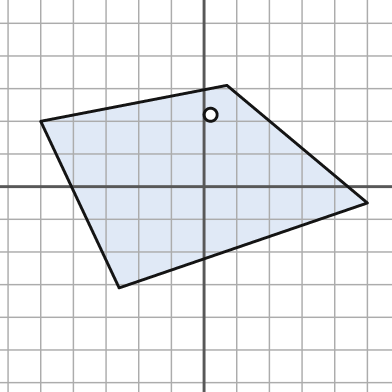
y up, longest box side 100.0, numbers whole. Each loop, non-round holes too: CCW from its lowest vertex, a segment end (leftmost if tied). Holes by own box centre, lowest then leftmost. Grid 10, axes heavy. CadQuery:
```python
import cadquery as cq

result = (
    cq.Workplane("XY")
    .moveTo(-26.0, -31.0)
    .lineTo(50.0, -5.0)
    .lineTo(7.0, 31.0)
    .lineTo(-50.0, 20.0)
    .close()
    .moveTo(2.0, 22.0)
    .circle(2.0)
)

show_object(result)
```